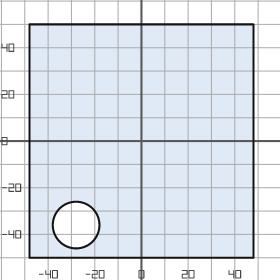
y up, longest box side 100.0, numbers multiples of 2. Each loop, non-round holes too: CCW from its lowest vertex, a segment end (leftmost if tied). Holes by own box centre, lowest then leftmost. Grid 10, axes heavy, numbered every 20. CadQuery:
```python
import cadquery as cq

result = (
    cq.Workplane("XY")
    .moveTo(-48.0, -50.0)
    .lineTo(48.0, -50.0)
    .lineTo(48.0, 50.0)
    .lineTo(-48.0, 50.0)
    .close()
    .moveTo(-28.0, -36.0)
    .circle(10.0)
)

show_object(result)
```